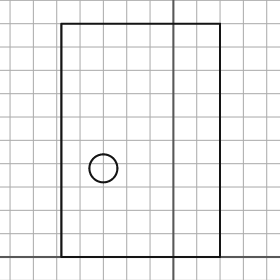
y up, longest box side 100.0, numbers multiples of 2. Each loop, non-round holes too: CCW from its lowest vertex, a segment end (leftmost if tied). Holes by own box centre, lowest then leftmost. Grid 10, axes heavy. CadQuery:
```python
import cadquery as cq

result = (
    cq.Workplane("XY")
    .moveTo(-48.0, 0.0)
    .lineTo(20.0, 0.0)
    .lineTo(20.0, 100.0)
    .lineTo(-48.0, 100.0)
    .close()
    .moveTo(-30.0, 38.0)
    .circle(6.0)
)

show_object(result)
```